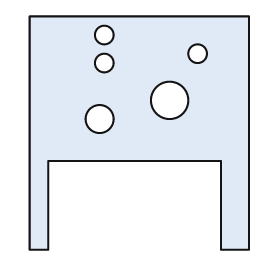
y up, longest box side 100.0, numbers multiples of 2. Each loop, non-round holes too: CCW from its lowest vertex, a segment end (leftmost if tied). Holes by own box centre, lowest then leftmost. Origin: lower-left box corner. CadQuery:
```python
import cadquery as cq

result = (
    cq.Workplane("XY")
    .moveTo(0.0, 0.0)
    .lineTo(8.0, 0.0)
    .lineTo(8.0, 38.0)
    .lineTo(82.0, 38.0)
    .lineTo(82.0, 0.0)
    .lineTo(94.0, 0.0)
    .lineTo(94.0, 100.0)
    .lineTo(0.0, 100.0)
    .close()
    .moveTo(30.0, 56.0)
    .circle(6.0)
    .moveTo(60.0, 64.0)
    .circle(8.0)
    .moveTo(32.0, 80.0)
    .circle(4.0)
    .moveTo(72.0, 84.0)
    .circle(4.0)
    .moveTo(32.0, 92.0)
    .circle(4.0)
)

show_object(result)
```